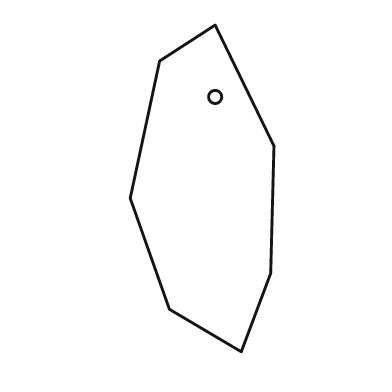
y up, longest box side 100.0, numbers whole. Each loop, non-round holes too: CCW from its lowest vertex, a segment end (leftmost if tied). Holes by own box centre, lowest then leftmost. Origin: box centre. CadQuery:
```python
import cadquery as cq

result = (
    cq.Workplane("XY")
    .moveTo(12.0, -50.0)
    .lineTo(21.0, -26.0)
    .lineTo(22.0, 13.0)
    .lineTo(4.0, 50.0)
    .lineTo(-13.0, 39.0)
    .lineTo(-22.0, -3.0)
    .lineTo(-10.0, -37.0)
    .close()
    .moveTo(4.0, 28.0)
    .circle(2.0)
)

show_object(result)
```